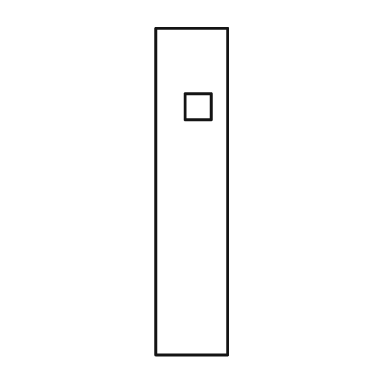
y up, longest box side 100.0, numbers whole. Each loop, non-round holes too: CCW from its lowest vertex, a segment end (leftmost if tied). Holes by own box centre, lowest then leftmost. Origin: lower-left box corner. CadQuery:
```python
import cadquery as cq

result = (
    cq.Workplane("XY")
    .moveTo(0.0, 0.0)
    .lineTo(22.0, 0.0)
    .lineTo(22.0, 100.0)
    .lineTo(0.0, 100.0)
    .close()
    .moveTo(9.0, 72.0)
    .lineTo(17.0, 72.0)
    .lineTo(17.0, 80.0)
    .lineTo(9.0, 80.0)
    .close()
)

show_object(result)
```